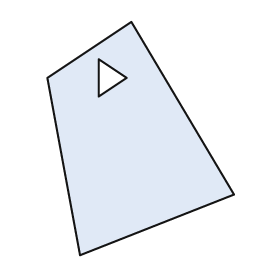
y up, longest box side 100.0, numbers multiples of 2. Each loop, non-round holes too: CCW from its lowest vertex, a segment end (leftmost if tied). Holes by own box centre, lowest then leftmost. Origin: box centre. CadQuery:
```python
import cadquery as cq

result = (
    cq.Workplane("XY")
    .moveTo(-26.0, -50.0)
    .lineTo(40.0, -24.0)
    .lineTo(-4.0, 50.0)
    .lineTo(-40.0, 26.0)
    .close()
    .moveTo(-18.0, 18.0)
    .lineTo(-6.0, 26.0)
    .lineTo(-18.0, 34.0)
    .close()
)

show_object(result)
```